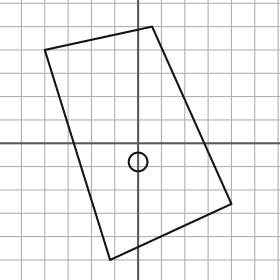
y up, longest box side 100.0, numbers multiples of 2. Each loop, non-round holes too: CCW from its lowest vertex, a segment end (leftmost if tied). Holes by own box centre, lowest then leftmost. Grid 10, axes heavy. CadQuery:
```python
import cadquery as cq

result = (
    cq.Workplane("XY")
    .moveTo(-12.0, -50.0)
    .lineTo(40.0, -26.0)
    .lineTo(6.0, 50.0)
    .lineTo(-40.0, 40.0)
    .close()
    .moveTo(0.0, -8.0)
    .circle(4.0)
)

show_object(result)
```